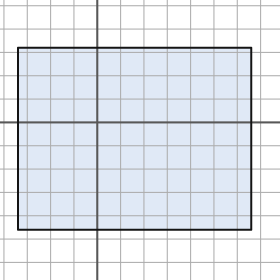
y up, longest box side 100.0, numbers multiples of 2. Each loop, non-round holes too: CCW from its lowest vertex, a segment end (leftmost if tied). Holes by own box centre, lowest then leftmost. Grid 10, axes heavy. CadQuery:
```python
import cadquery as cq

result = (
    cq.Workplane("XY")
    .moveTo(-34.0, -46.0)
    .lineTo(66.0, -46.0)
    .lineTo(66.0, 32.0)
    .lineTo(-34.0, 32.0)
    .close()
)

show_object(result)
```